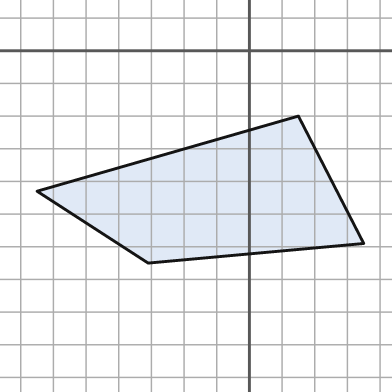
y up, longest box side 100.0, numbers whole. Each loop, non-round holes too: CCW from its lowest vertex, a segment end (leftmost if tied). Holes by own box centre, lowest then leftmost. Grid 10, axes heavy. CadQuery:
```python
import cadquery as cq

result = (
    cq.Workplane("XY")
    .moveTo(-31.0, -65.0)
    .lineTo(35.0, -59.0)
    .lineTo(15.0, -20.0)
    .lineTo(-65.0, -43.0)
    .close()
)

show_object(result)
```